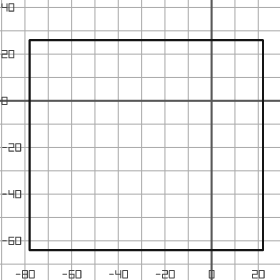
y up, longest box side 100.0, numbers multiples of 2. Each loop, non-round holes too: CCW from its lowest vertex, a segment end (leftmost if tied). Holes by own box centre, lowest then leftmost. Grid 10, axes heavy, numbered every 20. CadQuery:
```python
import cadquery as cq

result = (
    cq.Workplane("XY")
    .moveTo(-78.0, -64.0)
    .lineTo(22.0, -64.0)
    .lineTo(22.0, 26.0)
    .lineTo(-78.0, 26.0)
    .close()
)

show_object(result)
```